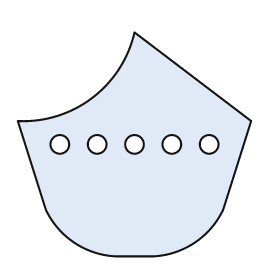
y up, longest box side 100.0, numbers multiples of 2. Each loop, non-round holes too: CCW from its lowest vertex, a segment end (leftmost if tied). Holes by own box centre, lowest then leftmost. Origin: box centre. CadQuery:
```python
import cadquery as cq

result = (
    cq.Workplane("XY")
    .moveTo(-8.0, -48.0)
    .lineTo(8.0, -48.0)
    .threePointArc((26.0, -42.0), (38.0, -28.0))
    .lineTo(50.0, 10.0)
    .lineTo(0.0, 48.0)
    .threePointArc((-18.0, 20.0), (-50.0, 10.0))
    .lineTo(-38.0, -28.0)
    .threePointArc((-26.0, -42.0), (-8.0, -48.0))
    .close()
    .moveTo(-32.0, 0.0)
    .circle(4.0)
    .moveTo(-16.0, 0.0)
    .circle(4.0)
    .moveTo(0.0, 0.0)
    .circle(4.0)
    .moveTo(16.0, 0.0)
    .circle(4.0)
    .moveTo(32.0, 0.0)
    .circle(4.0)
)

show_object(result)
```